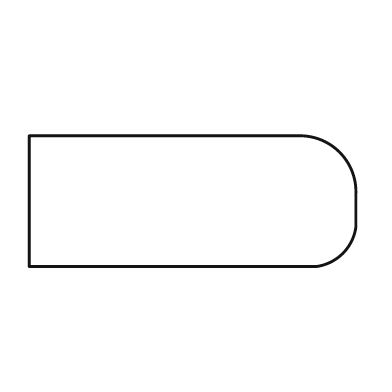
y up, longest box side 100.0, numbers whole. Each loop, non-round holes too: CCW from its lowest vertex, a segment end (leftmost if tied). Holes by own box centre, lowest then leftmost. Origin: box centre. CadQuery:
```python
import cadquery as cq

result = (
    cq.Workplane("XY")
    .moveTo(-50.0, -20.0)
    .lineTo(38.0, -20.0)
    .threePointArc((46.0, -16.0), (50.0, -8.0))
    .lineTo(50.0, 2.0)
    .threePointArc((45.0, 15.0), (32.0, 20.0))
    .lineTo(-50.0, 20.0)
    .close()
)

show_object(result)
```